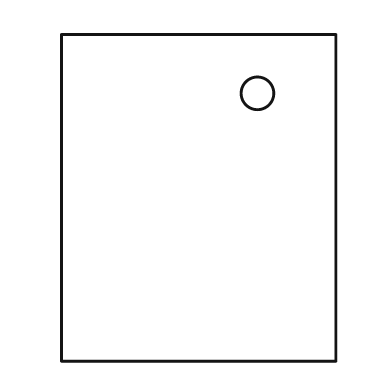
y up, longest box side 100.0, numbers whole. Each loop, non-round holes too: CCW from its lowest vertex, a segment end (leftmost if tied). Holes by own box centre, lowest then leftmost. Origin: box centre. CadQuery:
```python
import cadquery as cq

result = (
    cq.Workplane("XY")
    .moveTo(-42.0, -50.0)
    .lineTo(42.0, -50.0)
    .lineTo(42.0, 50.0)
    .lineTo(-42.0, 50.0)
    .close()
    .moveTo(18.0, 32.0)
    .circle(5.0)
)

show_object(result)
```